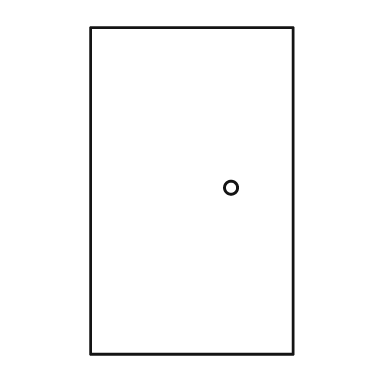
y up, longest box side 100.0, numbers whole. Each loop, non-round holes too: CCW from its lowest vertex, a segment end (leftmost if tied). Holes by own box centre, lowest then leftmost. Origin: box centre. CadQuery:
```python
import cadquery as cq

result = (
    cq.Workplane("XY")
    .moveTo(-31.0, -50.0)
    .lineTo(31.0, -50.0)
    .lineTo(31.0, 50.0)
    .lineTo(-31.0, 50.0)
    .close()
    .moveTo(12.0, 1.0)
    .circle(2.0)
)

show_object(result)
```